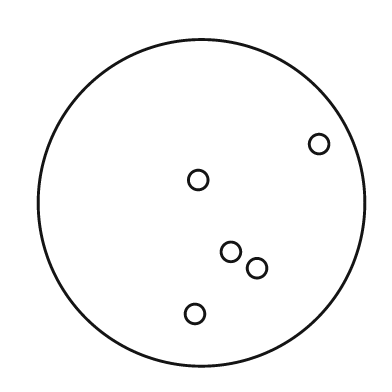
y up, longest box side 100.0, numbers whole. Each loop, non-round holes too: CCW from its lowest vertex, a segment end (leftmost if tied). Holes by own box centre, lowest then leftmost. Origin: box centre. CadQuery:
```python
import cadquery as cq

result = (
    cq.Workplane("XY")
    .moveTo(0.0, 0.0)
    .circle(50.0)
    .moveTo(-2.0, -34.0)
    .circle(3.0)
    .moveTo(17.0, -20.0)
    .circle(3.0)
    .moveTo(9.0, -15.0)
    .circle(3.0)
    .moveTo(-1.0, 7.0)
    .circle(3.0)
    .moveTo(36.0, 18.0)
    .circle(3.0)
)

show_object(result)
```